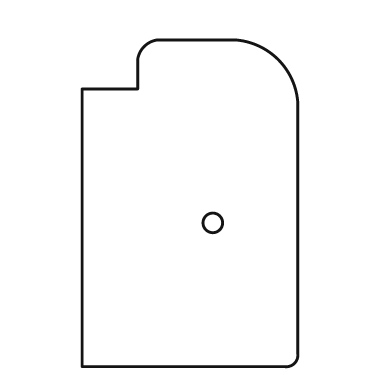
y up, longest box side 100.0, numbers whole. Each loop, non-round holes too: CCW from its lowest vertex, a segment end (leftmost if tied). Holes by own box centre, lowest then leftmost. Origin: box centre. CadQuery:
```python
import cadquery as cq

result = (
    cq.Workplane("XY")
    .moveTo(-33.0, -50.0)
    .lineTo(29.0, -50.0)
    .threePointArc((32.0, -49.0), (33.0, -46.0))
    .lineTo(33.0, 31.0)
    .threePointArc((27.0, 44.0), (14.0, 50.0))
    .lineTo(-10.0, 50.0)
    .threePointArc((-14.0, 48.0), (-16.0, 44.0))
    .lineTo(-16.0, 35.0)
    .lineTo(-33.0, 35.0)
    .close()
    .moveTo(7.0, -6.0)
    .circle(3.0)
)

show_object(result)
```